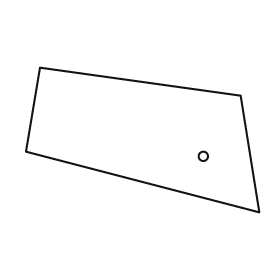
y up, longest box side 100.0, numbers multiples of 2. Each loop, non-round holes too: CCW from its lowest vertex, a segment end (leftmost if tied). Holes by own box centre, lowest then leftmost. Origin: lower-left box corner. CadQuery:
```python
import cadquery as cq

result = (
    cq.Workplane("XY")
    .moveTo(100.0, 0.0)
    .lineTo(92.0, 50.0)
    .lineTo(6.0, 62.0)
    .lineTo(0.0, 26.0)
    .close()
    .moveTo(76.0, 24.0)
    .circle(2.0)
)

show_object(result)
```